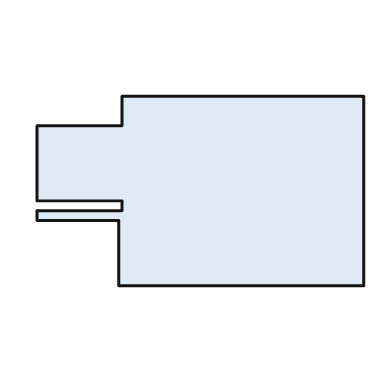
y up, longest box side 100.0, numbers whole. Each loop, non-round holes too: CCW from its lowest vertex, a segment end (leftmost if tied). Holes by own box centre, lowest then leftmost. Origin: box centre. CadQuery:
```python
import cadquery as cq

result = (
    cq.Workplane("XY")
    .moveTo(-25.0, -29.0)
    .lineTo(50.0, -29.0)
    .lineTo(50.0, 29.0)
    .lineTo(-24.0, 29.0)
    .lineTo(-24.0, 20.0)
    .lineTo(-50.0, 20.0)
    .lineTo(-50.0, -3.0)
    .lineTo(-24.0, -3.0)
    .lineTo(-24.0, -6.0)
    .lineTo(-50.0, -6.0)
    .lineTo(-50.0, -9.0)
    .lineTo(-25.0, -9.0)
    .close()
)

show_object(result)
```